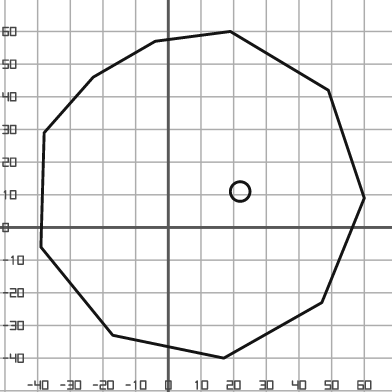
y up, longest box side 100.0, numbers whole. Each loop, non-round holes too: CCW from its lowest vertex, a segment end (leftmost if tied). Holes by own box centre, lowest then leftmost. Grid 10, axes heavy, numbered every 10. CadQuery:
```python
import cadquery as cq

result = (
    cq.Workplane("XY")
    .moveTo(17.0, -40.0)
    .lineTo(47.0, -23.0)
    .lineTo(60.0, 9.0)
    .lineTo(49.0, 42.0)
    .lineTo(19.0, 60.0)
    .lineTo(-4.0, 57.0)
    .lineTo(-23.0, 46.0)
    .lineTo(-38.0, 29.0)
    .lineTo(-39.0, -6.0)
    .lineTo(-17.0, -33.0)
    .close()
    .moveTo(22.0, 11.0)
    .circle(3.0)
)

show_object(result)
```